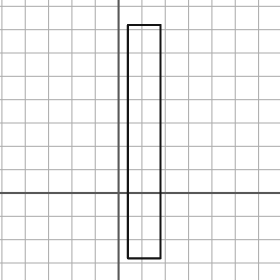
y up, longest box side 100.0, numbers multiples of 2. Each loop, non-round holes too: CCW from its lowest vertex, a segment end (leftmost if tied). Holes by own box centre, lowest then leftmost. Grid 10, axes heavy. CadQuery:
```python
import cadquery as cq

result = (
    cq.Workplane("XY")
    .moveTo(4.0, -28.0)
    .lineTo(18.0, -28.0)
    .lineTo(18.0, 72.0)
    .lineTo(4.0, 72.0)
    .close()
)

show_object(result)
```